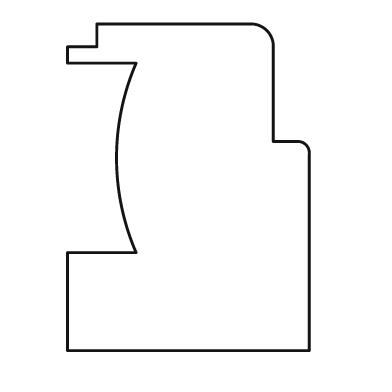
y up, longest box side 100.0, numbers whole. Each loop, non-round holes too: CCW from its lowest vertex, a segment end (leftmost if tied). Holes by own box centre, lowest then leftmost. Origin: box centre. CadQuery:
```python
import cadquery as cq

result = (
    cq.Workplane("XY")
    .moveTo(-37.0, -50.0)
    .lineTo(37.0, -50.0)
    .lineTo(37.0, 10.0)
    .threePointArc((36.0, 13.0), (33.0, 14.0))
    .lineTo(26.0, 14.0)
    .lineTo(26.0, 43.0)
    .threePointArc((24.0, 48.0), (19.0, 50.0))
    .lineTo(-28.0, 50.0)
    .lineTo(-28.0, 43.0)
    .lineTo(-37.0, 43.0)
    .lineTo(-37.0, 38.0)
    .lineTo(-16.0, 38.0)
    .threePointArc((-22.0, 9.0), (-16.0, -20.0))
    .lineTo(-37.0, -20.0)
    .close()
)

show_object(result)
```